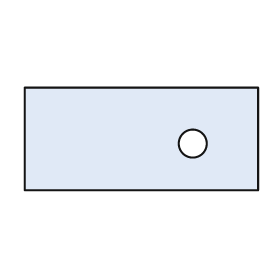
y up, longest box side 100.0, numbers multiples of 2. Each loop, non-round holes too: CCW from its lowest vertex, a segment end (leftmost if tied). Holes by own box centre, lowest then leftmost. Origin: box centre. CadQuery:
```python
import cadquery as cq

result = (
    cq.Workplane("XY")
    .moveTo(-50.0, -22.0)
    .lineTo(50.0, -22.0)
    .lineTo(50.0, 22.0)
    .lineTo(-50.0, 22.0)
    .close()
    .moveTo(22.0, -2.0)
    .circle(6.0)
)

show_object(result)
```